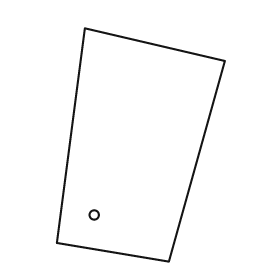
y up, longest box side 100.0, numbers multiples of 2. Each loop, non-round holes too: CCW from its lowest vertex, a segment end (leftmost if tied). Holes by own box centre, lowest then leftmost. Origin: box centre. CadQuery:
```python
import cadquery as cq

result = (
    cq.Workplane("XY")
    .moveTo(12.0, -50.0)
    .lineTo(36.0, 36.0)
    .lineTo(-24.0, 50.0)
    .lineTo(-36.0, -42.0)
    .close()
    .moveTo(-20.0, -30.0)
    .circle(2.0)
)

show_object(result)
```